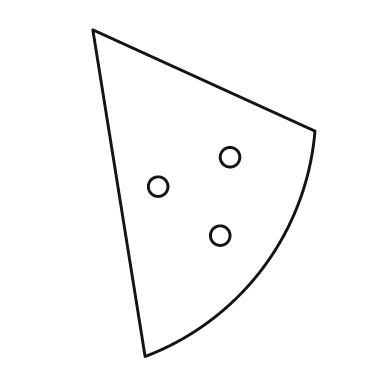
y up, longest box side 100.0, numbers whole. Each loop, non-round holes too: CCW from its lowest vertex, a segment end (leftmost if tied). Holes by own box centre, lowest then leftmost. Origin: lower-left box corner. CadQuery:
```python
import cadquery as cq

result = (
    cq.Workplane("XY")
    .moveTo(16.0, 0.0)
    .threePointArc((52.0, 27.0), (68.0, 69.0))
    .lineTo(0.0, 100.0)
    .close()
    .moveTo(39.0, 37.0)
    .circle(3.0)
    .moveTo(20.0, 52.0)
    .circle(3.0)
    .moveTo(42.0, 61.0)
    .circle(3.0)
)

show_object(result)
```